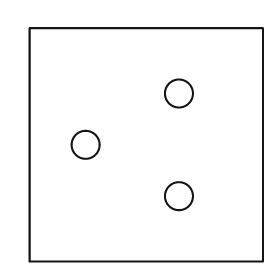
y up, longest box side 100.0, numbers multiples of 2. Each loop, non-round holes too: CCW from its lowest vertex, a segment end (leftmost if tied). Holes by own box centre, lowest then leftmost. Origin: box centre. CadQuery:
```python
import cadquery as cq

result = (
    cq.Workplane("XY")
    .moveTo(-50.0, -50.0)
    .lineTo(50.0, -50.0)
    .lineTo(50.0, 50.0)
    .lineTo(-50.0, 50.0)
    .close()
    .moveTo(14.0, -22.0)
    .circle(6.0)
    .moveTo(-26.0, 0.0)
    .circle(6.0)
    .moveTo(14.0, 22.0)
    .circle(6.0)
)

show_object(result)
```